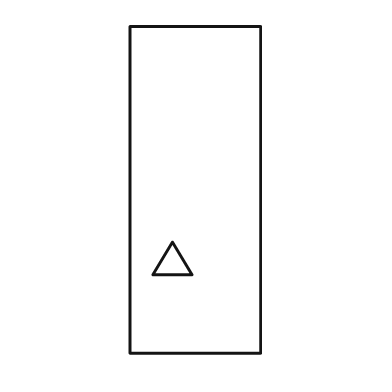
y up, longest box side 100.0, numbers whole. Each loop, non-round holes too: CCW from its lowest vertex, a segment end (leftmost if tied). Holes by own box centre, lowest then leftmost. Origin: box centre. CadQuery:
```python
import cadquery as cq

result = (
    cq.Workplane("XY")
    .moveTo(-20.0, -50.0)
    .lineTo(20.0, -50.0)
    .lineTo(20.0, 50.0)
    .lineTo(-20.0, 50.0)
    .close()
    .moveTo(-13.0, -26.0)
    .lineTo(-1.0, -26.0)
    .lineTo(-7.0, -16.0)
    .close()
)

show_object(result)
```